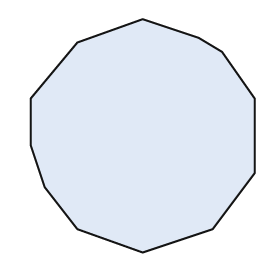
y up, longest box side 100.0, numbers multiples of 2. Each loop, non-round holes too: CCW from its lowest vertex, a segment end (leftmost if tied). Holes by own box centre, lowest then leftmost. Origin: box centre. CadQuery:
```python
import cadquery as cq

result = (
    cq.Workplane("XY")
    .moveTo(0.0, -50.0)
    .lineTo(30.0, -40.0)
    .lineTo(48.0, -16.0)
    .lineTo(48.0, 16.0)
    .lineTo(34.0, 36.0)
    .lineTo(24.0, 42.0)
    .lineTo(0.0, 50.0)
    .lineTo(-28.0, 40.0)
    .lineTo(-48.0, 16.0)
    .lineTo(-48.0, -4.0)
    .lineTo(-42.0, -22.0)
    .lineTo(-28.0, -40.0)
    .close()
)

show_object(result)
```